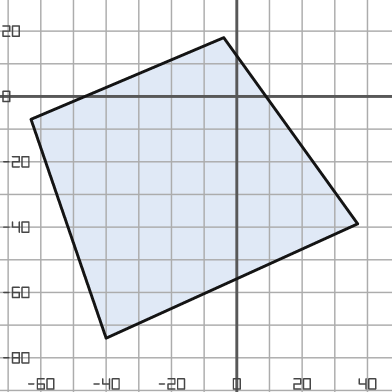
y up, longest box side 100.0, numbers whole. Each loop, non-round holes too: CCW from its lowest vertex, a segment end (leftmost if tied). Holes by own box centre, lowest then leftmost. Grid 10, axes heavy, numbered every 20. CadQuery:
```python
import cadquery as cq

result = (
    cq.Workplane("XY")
    .moveTo(-40.0, -74.0)
    .lineTo(37.0, -39.0)
    .lineTo(-4.0, 18.0)
    .lineTo(-63.0, -7.0)
    .close()
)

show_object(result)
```